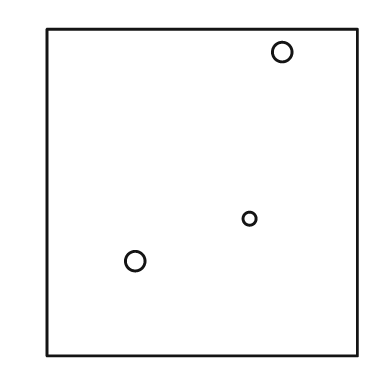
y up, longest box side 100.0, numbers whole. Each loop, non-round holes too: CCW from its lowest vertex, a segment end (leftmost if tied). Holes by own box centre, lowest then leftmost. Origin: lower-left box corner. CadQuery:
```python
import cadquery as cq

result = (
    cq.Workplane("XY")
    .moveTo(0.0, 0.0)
    .lineTo(95.0, 0.0)
    .lineTo(95.0, 100.0)
    .lineTo(0.0, 100.0)
    .close()
    .moveTo(27.0, 29.0)
    .circle(3.0)
    .moveTo(62.0, 42.0)
    .circle(2.0)
    .moveTo(72.0, 93.0)
    .circle(3.0)
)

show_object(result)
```